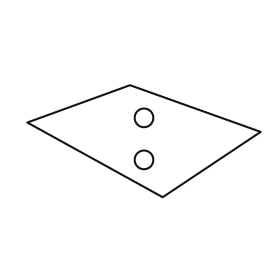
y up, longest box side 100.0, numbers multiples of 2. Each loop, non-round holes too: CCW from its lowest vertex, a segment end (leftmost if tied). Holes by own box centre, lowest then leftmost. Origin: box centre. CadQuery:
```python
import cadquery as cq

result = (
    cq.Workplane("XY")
    .moveTo(8.0, -24.0)
    .lineTo(50.0, 4.0)
    .lineTo(-6.0, 24.0)
    .lineTo(-50.0, 8.0)
    .close()
    .moveTo(0.0, -8.0)
    .circle(4.0)
    .moveTo(0.0, 10.0)
    .circle(4.0)
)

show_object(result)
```